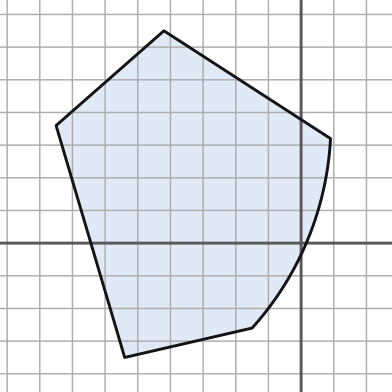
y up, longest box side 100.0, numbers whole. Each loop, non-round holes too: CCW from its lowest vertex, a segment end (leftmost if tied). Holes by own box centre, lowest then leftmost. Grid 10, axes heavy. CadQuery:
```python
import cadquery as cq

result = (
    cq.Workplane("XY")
    .moveTo(-54.0, -35.0)
    .lineTo(-15.0, -26.0)
    .threePointArc((2.0, 1.0), (9.0, 32.0))
    .lineTo(-42.0, 65.0)
    .lineTo(-75.0, 36.0)
    .close()
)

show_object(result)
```